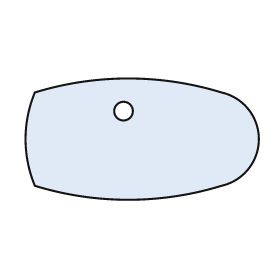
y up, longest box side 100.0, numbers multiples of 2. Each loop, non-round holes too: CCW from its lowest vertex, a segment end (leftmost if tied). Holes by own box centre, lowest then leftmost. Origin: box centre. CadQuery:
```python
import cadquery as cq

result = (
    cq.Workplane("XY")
    .moveTo(-46.0, -20.0)
    .threePointArc((-6.0, -26.0), (34.0, -20.0))
    .threePointArc((50.0, 0.0), (34.0, 20.0))
    .threePointArc((-6.0, 26.0), (-46.0, 20.0))
    .threePointArc((-50.0, 0.0), (-46.0, -20.0))
    .close()
    .moveTo(-8.0, 12.0)
    .circle(4.0)
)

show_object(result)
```